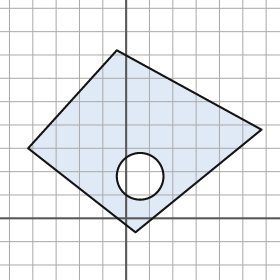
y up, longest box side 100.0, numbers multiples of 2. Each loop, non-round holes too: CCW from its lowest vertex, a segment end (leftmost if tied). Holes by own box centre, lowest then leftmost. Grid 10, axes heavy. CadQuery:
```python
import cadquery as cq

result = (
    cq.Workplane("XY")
    .moveTo(4.0, -6.0)
    .lineTo(58.0, 38.0)
    .lineTo(-4.0, 72.0)
    .lineTo(-42.0, 30.0)
    .close()
    .moveTo(6.0, 18.0)
    .circle(10.0)
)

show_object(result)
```